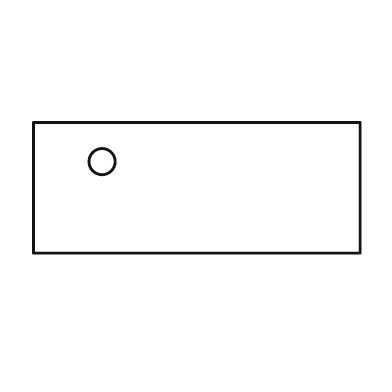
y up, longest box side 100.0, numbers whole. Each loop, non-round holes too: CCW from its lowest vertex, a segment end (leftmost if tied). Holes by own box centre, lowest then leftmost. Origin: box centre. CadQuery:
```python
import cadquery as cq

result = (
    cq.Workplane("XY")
    .moveTo(-50.0, -20.0)
    .lineTo(50.0, -20.0)
    .lineTo(50.0, 20.0)
    .lineTo(-50.0, 20.0)
    .close()
    .moveTo(-29.0, 8.0)
    .circle(4.0)
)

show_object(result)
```